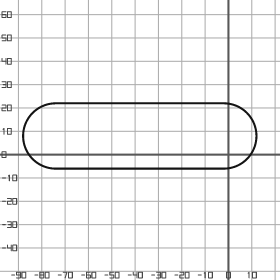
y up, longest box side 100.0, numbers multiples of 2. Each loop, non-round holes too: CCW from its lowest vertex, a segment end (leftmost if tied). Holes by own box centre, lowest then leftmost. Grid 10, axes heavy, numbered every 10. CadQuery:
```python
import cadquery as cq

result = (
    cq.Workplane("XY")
    .moveTo(-74.0, -6.0)
    .lineTo(-2.0, -6.0)
    .threePointArc((12.0, 8.0), (-2.0, 22.0))
    .lineTo(-74.0, 22.0)
    .threePointArc((-88.0, 8.0), (-74.0, -6.0))
    .close()
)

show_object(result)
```